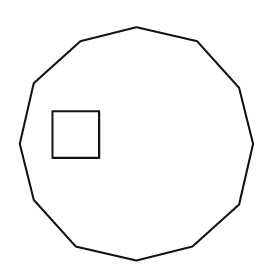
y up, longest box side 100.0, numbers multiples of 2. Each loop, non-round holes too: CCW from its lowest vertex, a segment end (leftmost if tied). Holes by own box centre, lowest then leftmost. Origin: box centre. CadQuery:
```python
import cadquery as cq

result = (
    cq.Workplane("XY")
    .moveTo(0.0, -50.0)
    .lineTo(24.0, -44.0)
    .lineTo(44.0, -26.0)
    .lineTo(50.0, 0.0)
    .lineTo(44.0, 24.0)
    .lineTo(26.0, 44.0)
    .lineTo(0.0, 50.0)
    .lineTo(-24.0, 44.0)
    .lineTo(-44.0, 26.0)
    .lineTo(-50.0, 0.0)
    .lineTo(-44.0, -24.0)
    .lineTo(-26.0, -44.0)
    .close()
    .moveTo(-36.0, -6.0)
    .lineTo(-16.0, -6.0)
    .lineTo(-16.0, 14.0)
    .lineTo(-36.0, 14.0)
    .close()
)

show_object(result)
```